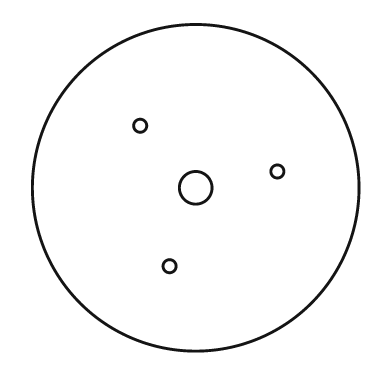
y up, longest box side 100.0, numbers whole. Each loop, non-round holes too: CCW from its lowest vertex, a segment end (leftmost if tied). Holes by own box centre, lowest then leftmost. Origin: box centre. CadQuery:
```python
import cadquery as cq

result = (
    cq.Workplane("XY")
    .moveTo(0.0, 0.0)
    .circle(50.0)
    .moveTo(-8.0, -24.0)
    .circle(2.0)
    .moveTo(0.0, 0.0)
    .circle(5.0)
    .moveTo(25.0, 5.0)
    .circle(2.0)
    .moveTo(-17.0, 19.0)
    .circle(2.0)
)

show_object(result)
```